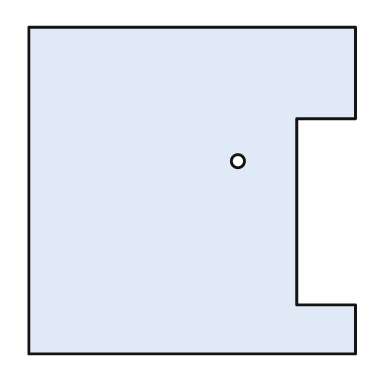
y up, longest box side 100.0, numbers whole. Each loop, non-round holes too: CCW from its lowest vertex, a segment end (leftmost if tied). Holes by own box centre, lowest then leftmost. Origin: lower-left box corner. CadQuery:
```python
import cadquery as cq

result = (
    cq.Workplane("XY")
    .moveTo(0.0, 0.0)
    .lineTo(100.0, 0.0)
    .lineTo(100.0, 15.0)
    .lineTo(82.0, 15.0)
    .lineTo(82.0, 72.0)
    .lineTo(100.0, 72.0)
    .lineTo(100.0, 100.0)
    .lineTo(0.0, 100.0)
    .close()
    .moveTo(64.0, 59.0)
    .circle(2.0)
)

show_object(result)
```